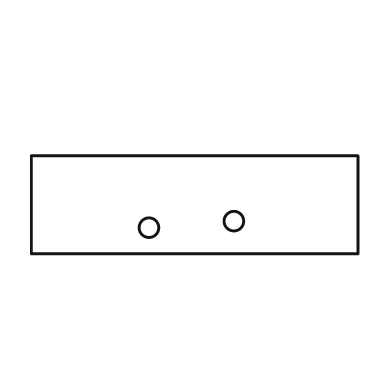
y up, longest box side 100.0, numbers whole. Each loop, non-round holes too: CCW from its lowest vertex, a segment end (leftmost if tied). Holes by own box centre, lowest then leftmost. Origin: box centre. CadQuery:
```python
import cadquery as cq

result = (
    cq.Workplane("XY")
    .moveTo(-50.0, -15.0)
    .lineTo(50.0, -15.0)
    .lineTo(50.0, 15.0)
    .lineTo(-50.0, 15.0)
    .close()
    .moveTo(-14.0, -7.0)
    .circle(3.0)
    .moveTo(12.0, -5.0)
    .circle(3.0)
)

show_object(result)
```